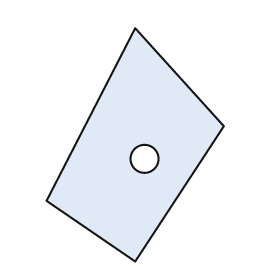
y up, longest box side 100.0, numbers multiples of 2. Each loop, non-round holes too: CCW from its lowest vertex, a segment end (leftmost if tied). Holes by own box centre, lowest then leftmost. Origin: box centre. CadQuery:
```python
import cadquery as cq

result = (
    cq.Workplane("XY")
    .moveTo(0.0, -50.0)
    .lineTo(38.0, 8.0)
    .lineTo(0.0, 50.0)
    .lineTo(-38.0, -24.0)
    .close()
    .moveTo(4.0, -6.0)
    .circle(6.0)
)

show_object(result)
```